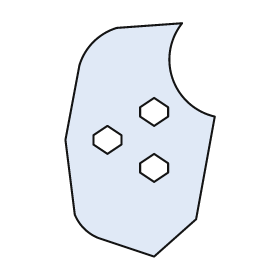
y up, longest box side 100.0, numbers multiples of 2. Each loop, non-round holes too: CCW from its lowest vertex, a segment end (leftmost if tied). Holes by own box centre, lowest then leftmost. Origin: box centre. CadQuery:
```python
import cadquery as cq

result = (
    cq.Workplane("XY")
    .moveTo(6.0, -50.0)
    .lineTo(24.0, -34.0)
    .lineTo(32.0, 10.0)
    .threePointArc((14.0, 26.0), (18.0, 50.0))
    .lineTo(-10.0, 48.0)
    .threePointArc((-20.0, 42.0), (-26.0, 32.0))
    .lineTo(-32.0, 0.0)
    .lineTo(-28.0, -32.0)
    .threePointArc((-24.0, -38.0), (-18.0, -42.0))
    .close()
    .moveTo(6.0, -18.0)
    .lineTo(12.0, -14.0)
    .lineTo(12.0, -10.0)
    .lineTo(6.0, -6.0)
    .lineTo(0.0, -10.0)
    .lineTo(0.0, -14.0)
    .close()
    .moveTo(-14.0, -6.0)
    .lineTo(-8.0, -2.0)
    .lineTo(-8.0, 2.0)
    .lineTo(-14.0, 6.0)
    .lineTo(-20.0, 2.0)
    .lineTo(-20.0, -2.0)
    .close()
    .moveTo(6.0, 6.0)
    .lineTo(12.0, 10.0)
    .lineTo(12.0, 14.0)
    .lineTo(6.0, 18.0)
    .lineTo(0.0, 14.0)
    .lineTo(0.0, 10.0)
    .close()
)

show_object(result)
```